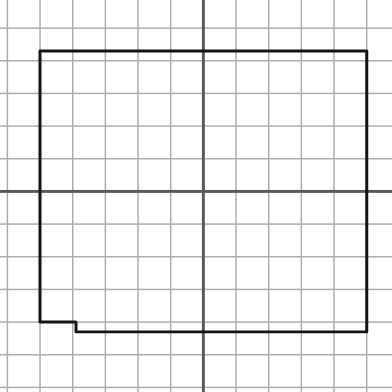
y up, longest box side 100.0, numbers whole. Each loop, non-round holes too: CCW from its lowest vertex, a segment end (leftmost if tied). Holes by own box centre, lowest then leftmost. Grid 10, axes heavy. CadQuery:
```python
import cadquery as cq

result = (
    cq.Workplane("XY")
    .moveTo(-39.0, -43.0)
    .lineTo(50.0, -43.0)
    .lineTo(50.0, 43.0)
    .lineTo(-50.0, 43.0)
    .lineTo(-50.0, -40.0)
    .lineTo(-39.0, -40.0)
    .close()
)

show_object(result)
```